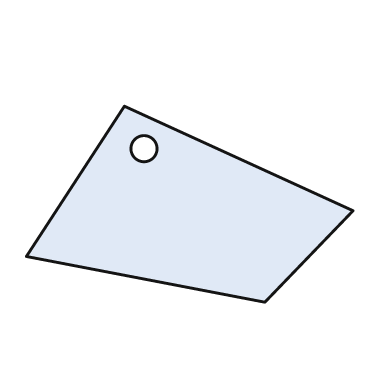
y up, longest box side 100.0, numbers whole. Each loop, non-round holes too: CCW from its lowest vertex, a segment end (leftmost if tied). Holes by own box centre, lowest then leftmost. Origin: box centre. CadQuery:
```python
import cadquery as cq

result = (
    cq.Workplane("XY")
    .moveTo(23.0, -30.0)
    .lineTo(50.0, -2.0)
    .lineTo(-20.0, 30.0)
    .lineTo(-50.0, -16.0)
    .close()
    .moveTo(-14.0, 17.0)
    .circle(4.0)
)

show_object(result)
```